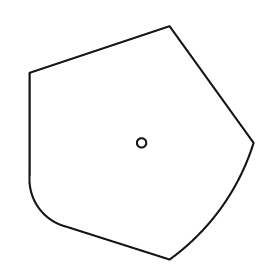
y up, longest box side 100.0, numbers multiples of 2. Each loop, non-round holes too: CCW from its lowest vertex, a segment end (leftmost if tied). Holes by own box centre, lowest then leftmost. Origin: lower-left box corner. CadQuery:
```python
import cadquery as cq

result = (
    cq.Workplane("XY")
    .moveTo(60.0, 0.0)
    .threePointArc((82.0, 22.0), (96.0, 50.0))
    .lineTo(60.0, 100.0)
    .lineTo(0.0, 80.0)
    .lineTo(0.0, 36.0)
    .threePointArc((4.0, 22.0), (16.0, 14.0))
    .close()
    .moveTo(48.0, 50.0)
    .circle(2.0)
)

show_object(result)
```